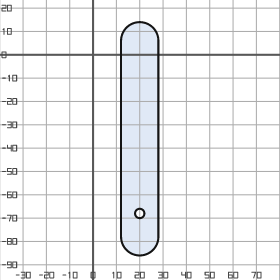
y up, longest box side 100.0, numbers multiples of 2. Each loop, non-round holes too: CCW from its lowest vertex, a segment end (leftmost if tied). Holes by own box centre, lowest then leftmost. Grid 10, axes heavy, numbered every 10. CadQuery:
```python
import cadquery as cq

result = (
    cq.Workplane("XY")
    .moveTo(12.0, -78.0)
    .threePointArc((20.0, -86.0), (28.0, -78.0))
    .lineTo(28.0, 6.0)
    .threePointArc((20.0, 14.0), (12.0, 6.0))
    .close()
    .moveTo(20.0, -68.0)
    .circle(2.0)
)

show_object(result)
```